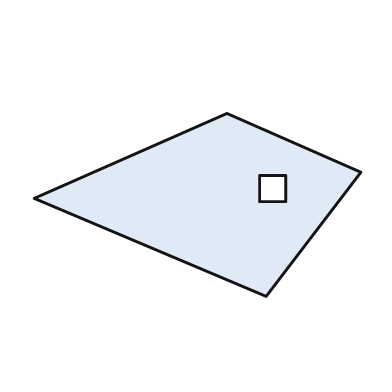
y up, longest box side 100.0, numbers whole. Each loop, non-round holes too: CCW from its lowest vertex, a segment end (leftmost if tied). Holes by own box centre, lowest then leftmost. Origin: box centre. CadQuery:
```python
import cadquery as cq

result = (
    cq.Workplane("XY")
    .moveTo(21.0, -28.0)
    .lineTo(50.0, 10.0)
    .lineTo(9.0, 28.0)
    .lineTo(-50.0, 2.0)
    .close()
    .moveTo(19.0, 1.0)
    .lineTo(27.0, 1.0)
    .lineTo(27.0, 9.0)
    .lineTo(19.0, 9.0)
    .close()
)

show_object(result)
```